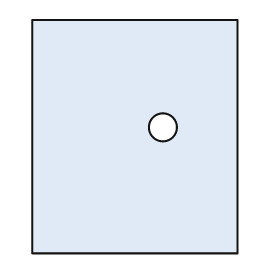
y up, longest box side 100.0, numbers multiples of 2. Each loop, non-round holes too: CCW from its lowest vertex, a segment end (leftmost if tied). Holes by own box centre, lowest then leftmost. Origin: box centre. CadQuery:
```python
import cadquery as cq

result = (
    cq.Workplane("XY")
    .moveTo(-44.0, -50.0)
    .lineTo(44.0, -50.0)
    .lineTo(44.0, 50.0)
    .lineTo(-44.0, 50.0)
    .close()
    .moveTo(12.0, 4.0)
    .circle(6.0)
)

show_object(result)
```